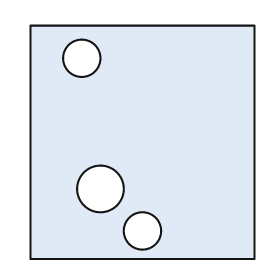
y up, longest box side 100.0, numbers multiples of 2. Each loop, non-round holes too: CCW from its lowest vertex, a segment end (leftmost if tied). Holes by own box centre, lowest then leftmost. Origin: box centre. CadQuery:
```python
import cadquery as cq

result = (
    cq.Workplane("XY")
    .moveTo(-48.0, -50.0)
    .lineTo(48.0, -50.0)
    .lineTo(48.0, 50.0)
    .lineTo(-48.0, 50.0)
    .close()
    .moveTo(0.0, -38.0)
    .circle(8.0)
    .moveTo(-18.0, -20.0)
    .circle(10.0)
    .moveTo(-26.0, 36.0)
    .circle(8.0)
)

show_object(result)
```